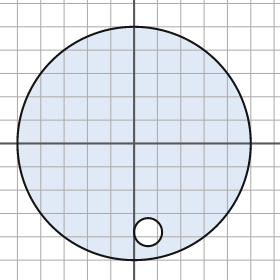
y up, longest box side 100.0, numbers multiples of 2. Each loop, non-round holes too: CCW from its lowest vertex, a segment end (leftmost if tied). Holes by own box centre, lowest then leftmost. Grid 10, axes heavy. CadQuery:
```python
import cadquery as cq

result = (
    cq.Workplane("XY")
    .moveTo(0.0, 0.0)
    .circle(50.0)
    .moveTo(6.0, -38.0)
    .circle(6.0)
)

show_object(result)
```